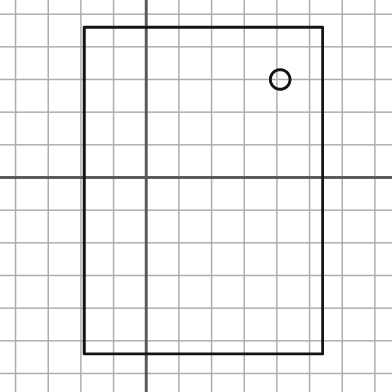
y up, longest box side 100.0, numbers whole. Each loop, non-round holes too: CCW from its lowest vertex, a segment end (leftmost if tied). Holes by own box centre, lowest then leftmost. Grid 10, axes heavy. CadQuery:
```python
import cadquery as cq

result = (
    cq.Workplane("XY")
    .moveTo(-19.0, -54.0)
    .lineTo(54.0, -54.0)
    .lineTo(54.0, 46.0)
    .lineTo(-19.0, 46.0)
    .close()
    .moveTo(41.0, 30.0)
    .circle(3.0)
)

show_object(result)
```